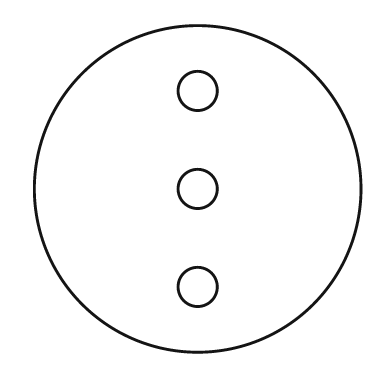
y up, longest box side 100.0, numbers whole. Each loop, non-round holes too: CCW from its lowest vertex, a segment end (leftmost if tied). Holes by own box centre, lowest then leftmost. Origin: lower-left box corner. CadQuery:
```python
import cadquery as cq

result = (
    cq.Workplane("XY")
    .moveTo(50.0, 50.0)
    .circle(50.0)
    .moveTo(50.0, 20.0)
    .circle(6.0)
    .moveTo(50.0, 50.0)
    .circle(6.0)
    .moveTo(50.0, 80.0)
    .circle(6.0)
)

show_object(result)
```